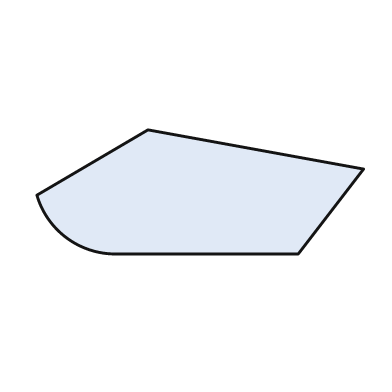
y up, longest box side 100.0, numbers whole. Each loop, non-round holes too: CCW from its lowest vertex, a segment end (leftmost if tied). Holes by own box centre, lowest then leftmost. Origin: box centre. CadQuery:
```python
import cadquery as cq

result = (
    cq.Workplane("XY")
    .moveTo(-26.0, -19.0)
    .lineTo(30.0, -19.0)
    .lineTo(50.0, 7.0)
    .lineTo(-16.0, 19.0)
    .lineTo(-50.0, -1.0)
    .threePointArc((-41.0, -14.0), (-26.0, -19.0))
    .close()
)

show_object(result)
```